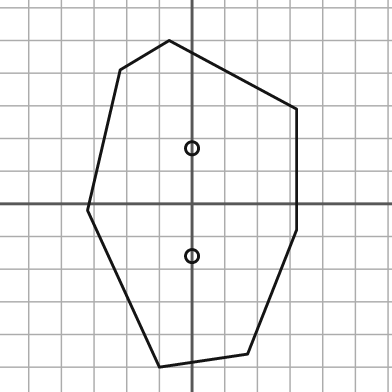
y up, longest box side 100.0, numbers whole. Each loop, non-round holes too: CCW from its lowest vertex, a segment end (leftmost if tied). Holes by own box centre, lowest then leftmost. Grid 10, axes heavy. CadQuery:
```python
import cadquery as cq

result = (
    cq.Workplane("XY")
    .moveTo(-10.0, -50.0)
    .lineTo(17.0, -46.0)
    .lineTo(32.0, -8.0)
    .lineTo(32.0, 29.0)
    .lineTo(-7.0, 50.0)
    .lineTo(-22.0, 41.0)
    .lineTo(-32.0, -2.0)
    .close()
    .moveTo(0.0, -16.0)
    .circle(2.0)
    .moveTo(0.0, 17.0)
    .circle(2.0)
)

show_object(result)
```